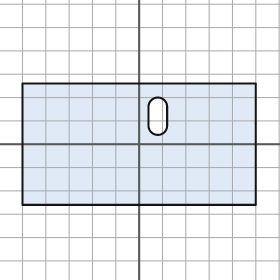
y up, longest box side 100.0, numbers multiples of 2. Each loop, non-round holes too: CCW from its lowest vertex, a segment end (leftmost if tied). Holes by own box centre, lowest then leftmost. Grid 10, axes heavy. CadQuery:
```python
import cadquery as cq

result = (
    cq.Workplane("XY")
    .moveTo(-50.0, -26.0)
    .lineTo(50.0, -26.0)
    .lineTo(50.0, 26.0)
    .lineTo(-50.0, 26.0)
    .close()
    .moveTo(4.0, 8.0)
    .threePointArc((8.0, 4.0), (12.0, 8.0))
    .lineTo(12.0, 16.0)
    .threePointArc((8.0, 20.0), (4.0, 16.0))
    .close()
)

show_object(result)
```